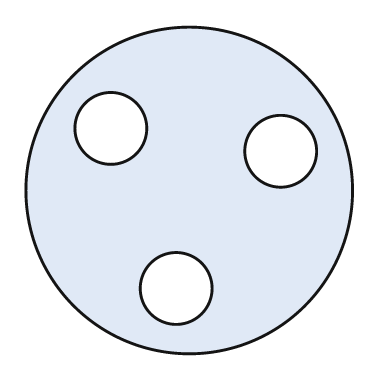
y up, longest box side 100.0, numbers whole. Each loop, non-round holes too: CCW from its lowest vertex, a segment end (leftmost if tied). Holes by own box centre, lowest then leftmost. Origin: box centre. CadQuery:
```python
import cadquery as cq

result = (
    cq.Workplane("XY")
    .moveTo(0.0, 0.0)
    .circle(50.0)
    .moveTo(-4.0, -30.0)
    .circle(11.0)
    .moveTo(28.0, 12.0)
    .circle(11.0)
    .moveTo(-24.0, 19.0)
    .circle(11.0)
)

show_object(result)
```